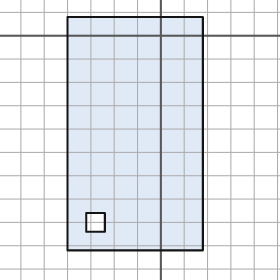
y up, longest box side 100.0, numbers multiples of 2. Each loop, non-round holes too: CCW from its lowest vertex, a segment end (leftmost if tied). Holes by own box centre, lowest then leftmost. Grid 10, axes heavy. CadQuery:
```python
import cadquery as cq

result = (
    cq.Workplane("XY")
    .moveTo(-40.0, -92.0)
    .lineTo(18.0, -92.0)
    .lineTo(18.0, 8.0)
    .lineTo(-40.0, 8.0)
    .close()
    .moveTo(-32.0, -84.0)
    .lineTo(-24.0, -84.0)
    .lineTo(-24.0, -76.0)
    .lineTo(-32.0, -76.0)
    .close()
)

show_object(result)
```